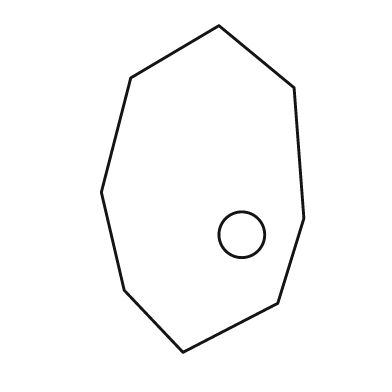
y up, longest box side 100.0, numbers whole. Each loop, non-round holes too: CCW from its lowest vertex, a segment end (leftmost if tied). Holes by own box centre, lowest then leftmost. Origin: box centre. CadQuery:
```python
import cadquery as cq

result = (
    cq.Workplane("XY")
    .moveTo(-6.0, -50.0)
    .lineTo(23.0, -35.0)
    .lineTo(31.0, -9.0)
    .lineTo(28.0, 31.0)
    .lineTo(5.0, 50.0)
    .lineTo(-22.0, 34.0)
    .lineTo(-31.0, -1.0)
    .lineTo(-24.0, -31.0)
    .close()
    .moveTo(12.0, -14.0)
    .circle(7.0)
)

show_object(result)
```